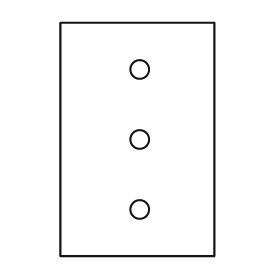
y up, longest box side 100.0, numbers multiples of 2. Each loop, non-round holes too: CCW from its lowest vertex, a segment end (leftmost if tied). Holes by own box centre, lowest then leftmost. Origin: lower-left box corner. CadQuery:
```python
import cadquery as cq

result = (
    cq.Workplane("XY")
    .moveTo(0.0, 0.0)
    .lineTo(66.0, 0.0)
    .lineTo(66.0, 100.0)
    .lineTo(0.0, 100.0)
    .close()
    .moveTo(34.0, 20.0)
    .circle(4.0)
    .moveTo(34.0, 50.0)
    .circle(4.0)
    .moveTo(34.0, 80.0)
    .circle(4.0)
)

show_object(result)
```